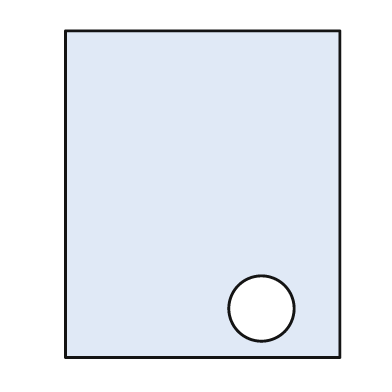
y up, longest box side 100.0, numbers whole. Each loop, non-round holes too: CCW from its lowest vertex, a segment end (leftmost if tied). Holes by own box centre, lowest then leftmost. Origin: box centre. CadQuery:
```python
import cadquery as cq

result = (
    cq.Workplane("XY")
    .moveTo(-42.0, -50.0)
    .lineTo(42.0, -50.0)
    .lineTo(42.0, 50.0)
    .lineTo(-42.0, 50.0)
    .close()
    .moveTo(18.0, -35.0)
    .circle(10.0)
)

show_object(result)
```